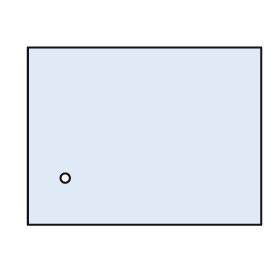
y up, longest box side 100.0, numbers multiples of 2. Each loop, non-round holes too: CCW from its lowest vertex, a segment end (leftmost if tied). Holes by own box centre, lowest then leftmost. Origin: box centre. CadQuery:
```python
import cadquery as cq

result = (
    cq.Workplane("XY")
    .moveTo(-50.0, -38.0)
    .lineTo(50.0, -38.0)
    .lineTo(50.0, 38.0)
    .lineTo(-50.0, 38.0)
    .close()
    .moveTo(-34.0, -18.0)
    .circle(2.0)
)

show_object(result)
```